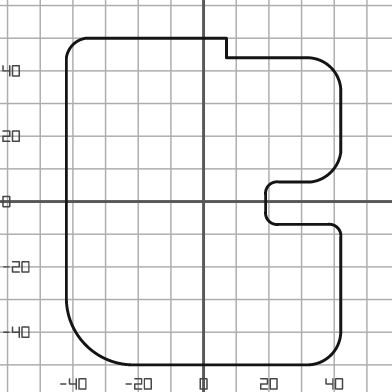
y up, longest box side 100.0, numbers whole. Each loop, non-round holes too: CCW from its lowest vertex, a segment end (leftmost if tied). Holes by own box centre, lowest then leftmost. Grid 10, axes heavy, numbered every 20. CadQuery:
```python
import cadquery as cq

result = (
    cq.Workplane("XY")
    .moveTo(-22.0, -50.0)
    .lineTo(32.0, -50.0)
    .threePointArc((39.0, -47.0), (42.0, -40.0))
    .lineTo(42.0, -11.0)
    .threePointArc((41.0, -8.0), (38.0, -7.0))
    .lineTo(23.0, -7.0)
    .threePointArc((20.0, -6.0), (19.0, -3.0))
    .lineTo(19.0, 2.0)
    .threePointArc((20.0, 5.0), (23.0, 6.0))
    .lineTo(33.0, 6.0)
    .threePointArc((39.0, 9.0), (42.0, 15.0))
    .lineTo(42.0, 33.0)
    .threePointArc((39.0, 41.0), (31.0, 44.0))
    .lineTo(7.0, 44.0)
    .lineTo(7.0, 50.0)
    .lineTo(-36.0, 50.0)
    .threePointArc((-40.0, 48.0), (-42.0, 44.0))
    .lineTo(-42.0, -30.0)
    .threePointArc((-36.0, -44.0), (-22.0, -50.0))
    .close()
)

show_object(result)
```